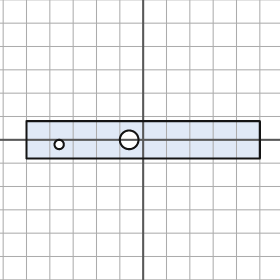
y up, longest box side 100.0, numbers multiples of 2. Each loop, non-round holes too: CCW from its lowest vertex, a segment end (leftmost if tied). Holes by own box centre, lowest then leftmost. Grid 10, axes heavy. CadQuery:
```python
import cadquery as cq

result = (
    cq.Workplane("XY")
    .moveTo(-50.0, -8.0)
    .lineTo(50.0, -8.0)
    .lineTo(50.0, 8.0)
    .lineTo(-50.0, 8.0)
    .close()
    .moveTo(-36.0, -2.0)
    .circle(2.0)
    .moveTo(-6.0, 0.0)
    .circle(4.0)
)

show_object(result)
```